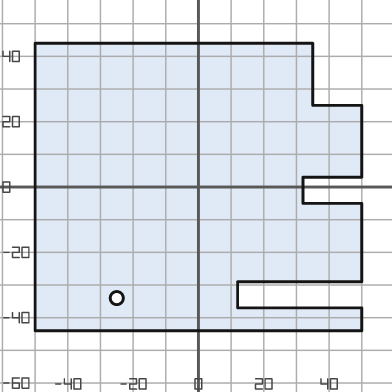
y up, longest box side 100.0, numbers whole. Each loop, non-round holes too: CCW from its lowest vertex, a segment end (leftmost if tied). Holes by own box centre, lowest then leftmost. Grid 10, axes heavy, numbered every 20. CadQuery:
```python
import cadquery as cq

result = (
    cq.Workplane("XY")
    .moveTo(-50.0, -44.0)
    .lineTo(50.0, -44.0)
    .lineTo(50.0, -37.0)
    .lineTo(12.0, -37.0)
    .lineTo(12.0, -29.0)
    .lineTo(50.0, -29.0)
    .lineTo(50.0, -5.0)
    .lineTo(32.0, -5.0)
    .lineTo(32.0, 3.0)
    .lineTo(50.0, 3.0)
    .lineTo(50.0, 25.0)
    .lineTo(35.0, 25.0)
    .lineTo(35.0, 44.0)
    .lineTo(-50.0, 44.0)
    .close()
    .moveTo(-25.0, -34.0)
    .circle(2.0)
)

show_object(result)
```